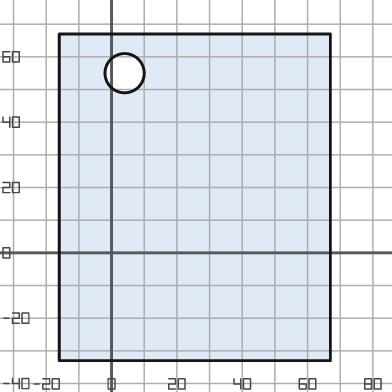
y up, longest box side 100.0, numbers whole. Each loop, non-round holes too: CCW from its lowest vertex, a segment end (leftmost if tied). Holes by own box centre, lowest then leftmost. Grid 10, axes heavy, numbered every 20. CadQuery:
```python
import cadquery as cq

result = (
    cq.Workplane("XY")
    .moveTo(-16.0, -33.0)
    .lineTo(67.0, -33.0)
    .lineTo(67.0, 67.0)
    .lineTo(-16.0, 67.0)
    .close()
    .moveTo(4.0, 55.0)
    .circle(6.0)
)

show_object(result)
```